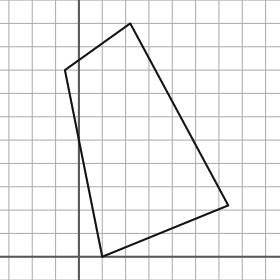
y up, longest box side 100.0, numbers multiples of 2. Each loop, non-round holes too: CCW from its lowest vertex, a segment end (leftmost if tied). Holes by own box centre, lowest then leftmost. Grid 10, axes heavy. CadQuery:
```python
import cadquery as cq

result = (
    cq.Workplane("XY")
    .moveTo(10.0, 0.0)
    .lineTo(64.0, 22.0)
    .lineTo(22.0, 100.0)
    .lineTo(-6.0, 80.0)
    .close()
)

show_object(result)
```